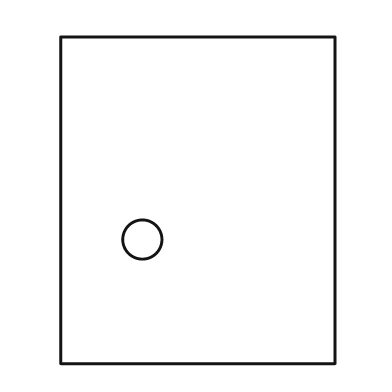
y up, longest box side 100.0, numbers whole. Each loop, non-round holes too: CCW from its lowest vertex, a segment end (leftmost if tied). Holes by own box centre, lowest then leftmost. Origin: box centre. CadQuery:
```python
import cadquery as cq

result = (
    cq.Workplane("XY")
    .moveTo(-42.0, -50.0)
    .lineTo(42.0, -50.0)
    .lineTo(42.0, 50.0)
    .lineTo(-42.0, 50.0)
    .close()
    .moveTo(-17.0, -12.0)
    .circle(6.0)
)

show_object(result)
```